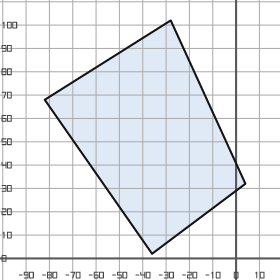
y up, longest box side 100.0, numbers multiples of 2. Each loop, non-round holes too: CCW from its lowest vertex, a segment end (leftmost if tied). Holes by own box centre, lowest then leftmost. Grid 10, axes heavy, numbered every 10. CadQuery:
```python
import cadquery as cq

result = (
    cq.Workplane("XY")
    .moveTo(-36.0, 2.0)
    .lineTo(4.0, 32.0)
    .lineTo(-28.0, 102.0)
    .lineTo(-82.0, 68.0)
    .close()
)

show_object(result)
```